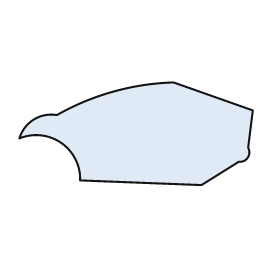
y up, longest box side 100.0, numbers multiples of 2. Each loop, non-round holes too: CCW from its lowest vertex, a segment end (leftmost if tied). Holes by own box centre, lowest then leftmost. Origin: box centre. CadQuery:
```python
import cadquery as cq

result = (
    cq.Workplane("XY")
    .moveTo(28.0, -22.0)
    .lineTo(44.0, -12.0)
    .threePointArc((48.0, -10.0), (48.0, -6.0))
    .lineTo(50.0, 10.0)
    .lineTo(16.0, 22.0)
    .threePointArc((-10.0, 18.0), (-34.0, 8.0))
    .threePointArc((-44.0, 6.0), (-50.0, -2.0))
    .threePointArc((-32.0, -4.0), (-24.0, -20.0))
    .close()
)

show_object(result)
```